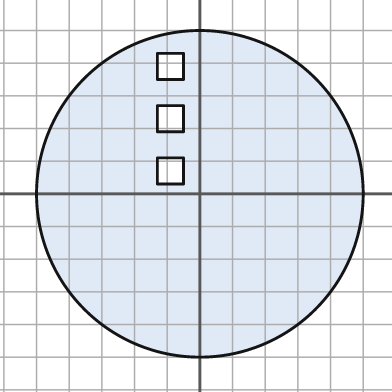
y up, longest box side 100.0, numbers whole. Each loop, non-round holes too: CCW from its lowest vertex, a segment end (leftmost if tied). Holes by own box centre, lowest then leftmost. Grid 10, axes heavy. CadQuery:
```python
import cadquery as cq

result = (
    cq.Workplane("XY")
    .moveTo(0.0, 0.0)
    .circle(50.0)
    .moveTo(-13.0, 3.0)
    .lineTo(-5.0, 3.0)
    .lineTo(-5.0, 11.0)
    .lineTo(-13.0, 11.0)
    .close()
    .moveTo(-13.0, 19.0)
    .lineTo(-5.0, 19.0)
    .lineTo(-5.0, 27.0)
    .lineTo(-13.0, 27.0)
    .close()
    .moveTo(-13.0, 35.0)
    .lineTo(-5.0, 35.0)
    .lineTo(-5.0, 43.0)
    .lineTo(-13.0, 43.0)
    .close()
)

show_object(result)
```